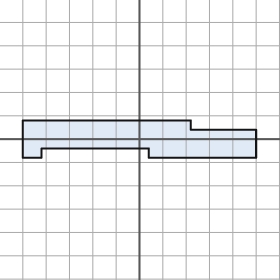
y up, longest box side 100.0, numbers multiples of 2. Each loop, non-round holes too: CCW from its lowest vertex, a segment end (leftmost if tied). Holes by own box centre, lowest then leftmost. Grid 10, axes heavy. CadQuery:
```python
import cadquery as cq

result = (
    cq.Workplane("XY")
    .moveTo(-50.0, -8.0)
    .lineTo(-42.0, -8.0)
    .lineTo(-42.0, -4.0)
    .lineTo(4.0, -4.0)
    .lineTo(4.0, -8.0)
    .lineTo(50.0, -8.0)
    .lineTo(50.0, 4.0)
    .lineTo(22.0, 4.0)
    .lineTo(22.0, 8.0)
    .lineTo(-50.0, 8.0)
    .close()
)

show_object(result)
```